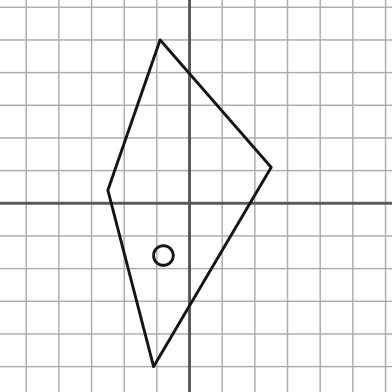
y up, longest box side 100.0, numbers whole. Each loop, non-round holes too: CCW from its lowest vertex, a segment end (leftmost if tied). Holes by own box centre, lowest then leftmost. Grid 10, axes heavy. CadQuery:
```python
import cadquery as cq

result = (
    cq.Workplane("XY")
    .moveTo(-11.0, -50.0)
    .lineTo(25.0, 11.0)
    .lineTo(-9.0, 50.0)
    .lineTo(-25.0, 4.0)
    .close()
    .moveTo(-8.0, -16.0)
    .circle(3.0)
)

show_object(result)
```